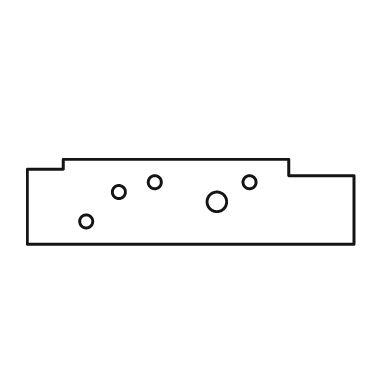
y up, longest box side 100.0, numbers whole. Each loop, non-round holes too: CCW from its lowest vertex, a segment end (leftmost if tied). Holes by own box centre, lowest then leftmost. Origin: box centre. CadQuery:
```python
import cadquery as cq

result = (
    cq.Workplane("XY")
    .moveTo(-50.0, -13.0)
    .lineTo(50.0, -13.0)
    .lineTo(50.0, 8.0)
    .lineTo(30.0, 8.0)
    .lineTo(30.0, 13.0)
    .lineTo(-39.0, 13.0)
    .lineTo(-39.0, 10.0)
    .lineTo(-50.0, 10.0)
    .close()
    .moveTo(-32.0, -6.0)
    .circle(2.0)
    .moveTo(8.0, 0.0)
    .circle(3.0)
    .moveTo(-22.0, 3.0)
    .circle(2.0)
    .moveTo(-11.0, 6.0)
    .circle(2.0)
    .moveTo(18.0, 6.0)
    .circle(2.0)
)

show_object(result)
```